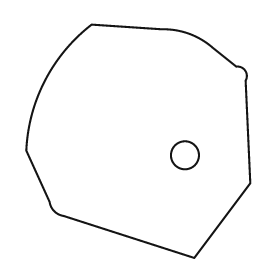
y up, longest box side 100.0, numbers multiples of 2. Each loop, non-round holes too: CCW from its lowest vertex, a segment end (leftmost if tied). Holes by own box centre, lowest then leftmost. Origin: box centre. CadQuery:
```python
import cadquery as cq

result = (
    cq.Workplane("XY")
    .moveTo(24.0, -50.0)
    .lineTo(48.0, -18.0)
    .lineTo(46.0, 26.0)
    .threePointArc((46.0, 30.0), (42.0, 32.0))
    .lineTo(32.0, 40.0)
    .threePointArc((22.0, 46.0), (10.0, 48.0))
    .lineTo(-20.0, 50.0)
    .threePointArc((-40.0, 26.0), (-48.0, -4.0))
    .lineTo(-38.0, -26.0)
    .threePointArc((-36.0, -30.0), (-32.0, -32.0))
    .close()
    .moveTo(20.0, -6.0)
    .circle(6.0)
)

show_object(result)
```